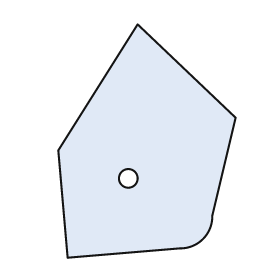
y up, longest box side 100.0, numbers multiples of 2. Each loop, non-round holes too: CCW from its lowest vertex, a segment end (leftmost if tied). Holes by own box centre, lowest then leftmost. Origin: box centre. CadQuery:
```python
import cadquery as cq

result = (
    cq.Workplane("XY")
    .moveTo(-34.0, -50.0)
    .lineTo(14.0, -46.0)
    .threePointArc((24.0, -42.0), (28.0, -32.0))
    .lineTo(38.0, 10.0)
    .lineTo(-4.0, 50.0)
    .lineTo(-38.0, -4.0)
    .close()
    .moveTo(-8.0, -16.0)
    .circle(4.0)
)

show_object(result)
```